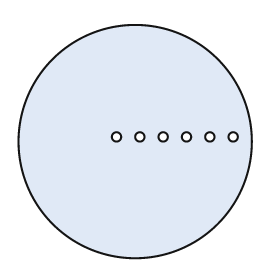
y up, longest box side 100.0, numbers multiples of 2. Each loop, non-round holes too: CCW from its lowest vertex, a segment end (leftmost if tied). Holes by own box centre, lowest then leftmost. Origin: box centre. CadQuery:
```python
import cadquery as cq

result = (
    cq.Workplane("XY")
    .moveTo(0.0, 0.0)
    .circle(50.0)
    .moveTo(-8.0, 2.0)
    .circle(2.0)
    .moveTo(2.0, 2.0)
    .circle(2.0)
    .moveTo(12.0, 2.0)
    .circle(2.0)
    .moveTo(22.0, 2.0)
    .circle(2.0)
    .moveTo(32.0, 2.0)
    .circle(2.0)
    .moveTo(42.0, 2.0)
    .circle(2.0)
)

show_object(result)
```